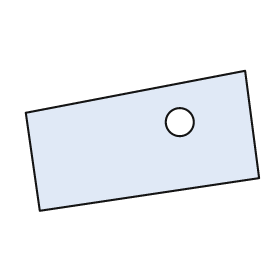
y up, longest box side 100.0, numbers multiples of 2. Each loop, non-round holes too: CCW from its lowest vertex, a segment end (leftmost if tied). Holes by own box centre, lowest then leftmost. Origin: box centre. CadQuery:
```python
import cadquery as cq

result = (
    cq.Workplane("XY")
    .moveTo(-44.0, -30.0)
    .lineTo(50.0, -16.0)
    .lineTo(44.0, 30.0)
    .lineTo(-50.0, 12.0)
    .close()
    .moveTo(16.0, 8.0)
    .circle(6.0)
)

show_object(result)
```